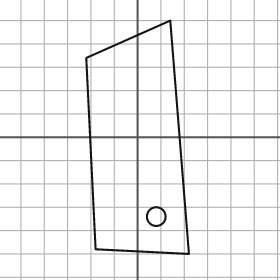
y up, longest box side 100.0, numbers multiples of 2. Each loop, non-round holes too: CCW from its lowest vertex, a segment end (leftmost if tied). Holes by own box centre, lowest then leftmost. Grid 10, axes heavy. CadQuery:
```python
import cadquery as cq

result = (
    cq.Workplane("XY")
    .moveTo(22.0, -50.0)
    .lineTo(14.0, 50.0)
    .lineTo(-22.0, 34.0)
    .lineTo(-18.0, -48.0)
    .close()
    .moveTo(8.0, -34.0)
    .circle(4.0)
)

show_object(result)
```